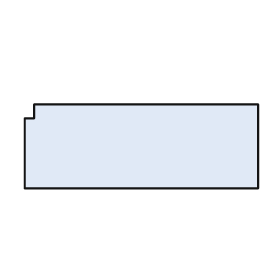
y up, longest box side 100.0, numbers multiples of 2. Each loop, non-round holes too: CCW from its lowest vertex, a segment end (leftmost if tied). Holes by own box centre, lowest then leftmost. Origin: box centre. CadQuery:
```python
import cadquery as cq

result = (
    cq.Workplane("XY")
    .moveTo(-50.0, -18.0)
    .lineTo(50.0, -18.0)
    .lineTo(50.0, 18.0)
    .lineTo(-46.0, 18.0)
    .lineTo(-46.0, 12.0)
    .lineTo(-50.0, 12.0)
    .close()
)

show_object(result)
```